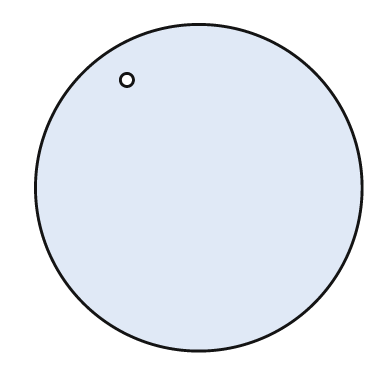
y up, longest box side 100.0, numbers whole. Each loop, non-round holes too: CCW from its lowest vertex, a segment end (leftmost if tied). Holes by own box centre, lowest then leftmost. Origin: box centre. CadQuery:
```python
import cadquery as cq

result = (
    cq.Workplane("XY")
    .moveTo(0.0, 0.0)
    .circle(50.0)
    .moveTo(-22.0, 33.0)
    .circle(2.0)
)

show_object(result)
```